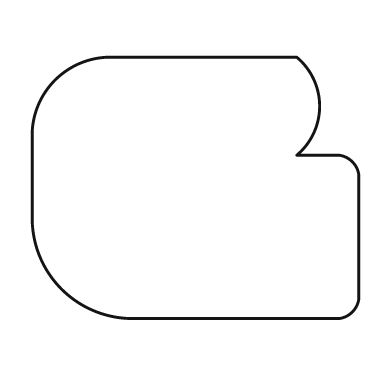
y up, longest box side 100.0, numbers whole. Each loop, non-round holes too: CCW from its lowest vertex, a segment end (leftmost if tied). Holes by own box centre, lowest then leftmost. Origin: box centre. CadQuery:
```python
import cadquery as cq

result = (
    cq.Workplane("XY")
    .moveTo(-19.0, -40.0)
    .lineTo(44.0, -40.0)
    .threePointArc((48.0, -38.0), (50.0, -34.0))
    .lineTo(50.0, 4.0)
    .threePointArc((48.0, 8.0), (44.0, 10.0))
    .lineTo(31.0, 10.0)
    .threePointArc((38.0, 25.0), (31.0, 40.0))
    .lineTo(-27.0, 40.0)
    .threePointArc((-43.0, 33.0), (-50.0, 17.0))
    .lineTo(-50.0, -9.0)
    .threePointArc((-41.0, -31.0), (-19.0, -40.0))
    .close()
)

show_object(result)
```